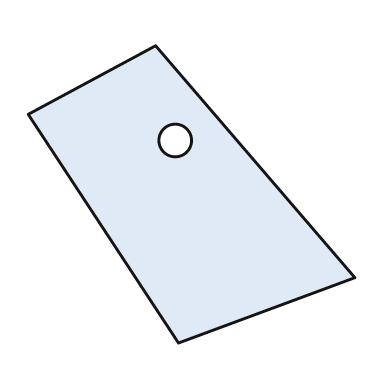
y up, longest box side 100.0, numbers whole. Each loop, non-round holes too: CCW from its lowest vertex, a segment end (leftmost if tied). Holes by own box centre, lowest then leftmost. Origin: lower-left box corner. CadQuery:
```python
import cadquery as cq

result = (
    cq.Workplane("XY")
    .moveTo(46.0, 0.0)
    .lineTo(100.0, 20.0)
    .lineTo(39.0, 91.0)
    .lineTo(0.0, 70.0)
    .close()
    .moveTo(45.0, 62.0)
    .circle(5.0)
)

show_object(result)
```